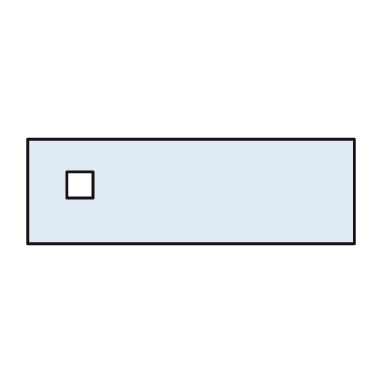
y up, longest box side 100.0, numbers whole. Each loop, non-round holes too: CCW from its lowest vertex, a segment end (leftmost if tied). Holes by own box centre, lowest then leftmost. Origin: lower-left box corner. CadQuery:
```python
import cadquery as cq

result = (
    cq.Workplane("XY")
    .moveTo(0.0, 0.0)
    .lineTo(100.0, 0.0)
    .lineTo(100.0, 32.0)
    .lineTo(0.0, 32.0)
    .close()
    .moveTo(12.0, 14.0)
    .lineTo(20.0, 14.0)
    .lineTo(20.0, 22.0)
    .lineTo(12.0, 22.0)
    .close()
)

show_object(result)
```